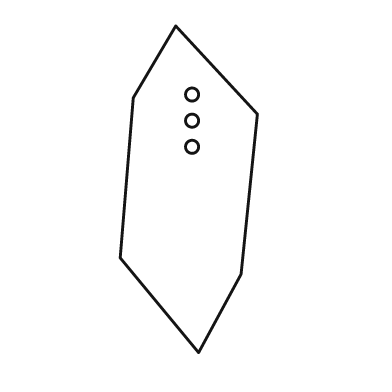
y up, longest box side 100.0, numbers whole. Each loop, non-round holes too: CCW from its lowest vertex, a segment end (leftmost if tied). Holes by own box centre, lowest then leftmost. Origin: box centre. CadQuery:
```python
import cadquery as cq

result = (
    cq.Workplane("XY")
    .moveTo(3.0, -50.0)
    .lineTo(16.0, -26.0)
    .lineTo(21.0, 23.0)
    .lineTo(-4.0, 50.0)
    .lineTo(-17.0, 28.0)
    .lineTo(-21.0, -21.0)
    .close()
    .moveTo(1.0, 13.0)
    .circle(2.0)
    .moveTo(1.0, 21.0)
    .circle(2.0)
    .moveTo(1.0, 29.0)
    .circle(2.0)
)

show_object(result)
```